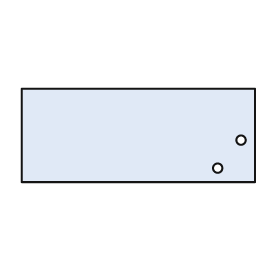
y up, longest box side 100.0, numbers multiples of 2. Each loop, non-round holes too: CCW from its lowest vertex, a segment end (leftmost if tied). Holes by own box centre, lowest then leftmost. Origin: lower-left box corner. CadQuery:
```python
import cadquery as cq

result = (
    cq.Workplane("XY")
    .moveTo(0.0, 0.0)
    .lineTo(100.0, 0.0)
    .lineTo(100.0, 40.0)
    .lineTo(0.0, 40.0)
    .close()
    .moveTo(84.0, 6.0)
    .circle(2.0)
    .moveTo(94.0, 18.0)
    .circle(2.0)
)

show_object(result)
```